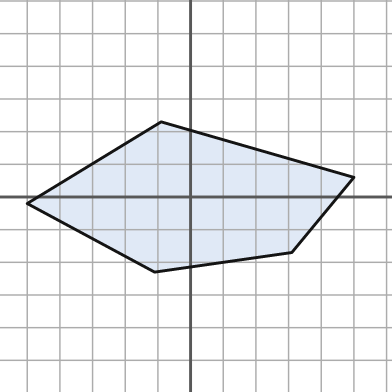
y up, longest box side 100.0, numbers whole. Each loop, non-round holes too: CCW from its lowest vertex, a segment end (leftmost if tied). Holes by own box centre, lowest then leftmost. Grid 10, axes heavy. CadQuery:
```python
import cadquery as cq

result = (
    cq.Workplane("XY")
    .moveTo(-11.0, -23.0)
    .lineTo(31.0, -17.0)
    .lineTo(50.0, 6.0)
    .lineTo(-9.0, 23.0)
    .lineTo(-50.0, -2.0)
    .close()
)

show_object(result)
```